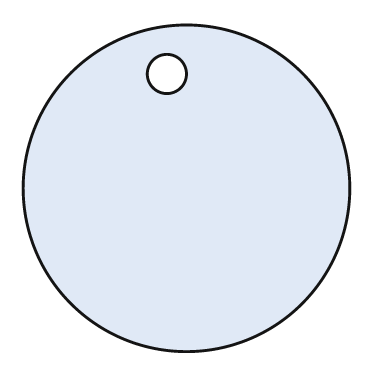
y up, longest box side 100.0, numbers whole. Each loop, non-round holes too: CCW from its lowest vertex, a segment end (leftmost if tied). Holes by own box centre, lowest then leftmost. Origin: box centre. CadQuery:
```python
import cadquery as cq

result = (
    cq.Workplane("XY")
    .moveTo(0.0, 0.0)
    .circle(50.0)
    .moveTo(-6.0, 35.0)
    .circle(6.0)
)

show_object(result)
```